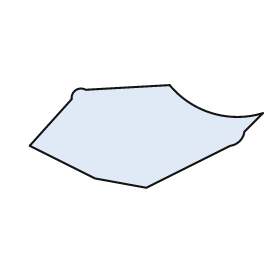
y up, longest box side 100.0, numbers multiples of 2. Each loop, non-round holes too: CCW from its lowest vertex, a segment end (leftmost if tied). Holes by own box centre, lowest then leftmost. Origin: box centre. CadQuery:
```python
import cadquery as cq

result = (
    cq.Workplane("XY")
    .moveTo(0.0, -22.0)
    .lineTo(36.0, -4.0)
    .threePointArc((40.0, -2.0), (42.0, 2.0))
    .lineTo(50.0, 10.0)
    .threePointArc((28.0, 10.0), (10.0, 22.0))
    .lineTo(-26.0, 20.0)
    .threePointArc((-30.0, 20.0), (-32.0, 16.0))
    .lineTo(-50.0, -4.0)
    .lineTo(-22.0, -18.0)
    .close()
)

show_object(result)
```